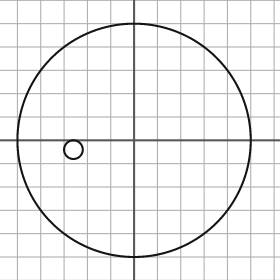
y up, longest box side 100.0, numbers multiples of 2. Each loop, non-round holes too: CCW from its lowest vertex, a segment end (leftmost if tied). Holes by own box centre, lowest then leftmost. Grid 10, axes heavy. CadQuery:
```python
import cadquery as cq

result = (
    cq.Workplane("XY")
    .moveTo(0.0, 0.0)
    .circle(50.0)
    .moveTo(-26.0, -4.0)
    .circle(4.0)
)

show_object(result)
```